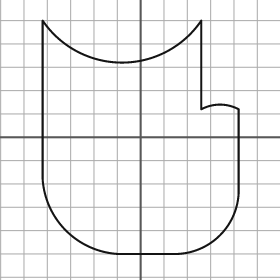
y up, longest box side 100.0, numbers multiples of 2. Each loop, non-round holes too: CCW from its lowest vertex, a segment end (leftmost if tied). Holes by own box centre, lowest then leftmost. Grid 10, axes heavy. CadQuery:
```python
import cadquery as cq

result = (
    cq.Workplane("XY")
    .moveTo(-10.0, -50.0)
    .lineTo(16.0, -50.0)
    .threePointArc((34.0, -42.0), (42.0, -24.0))
    .lineTo(42.0, 12.0)
    .threePointArc((34.0, 14.0), (26.0, 12.0))
    .lineTo(26.0, 50.0)
    .threePointArc((-8.0, 32.0), (-42.0, 50.0))
    .lineTo(-42.0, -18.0)
    .threePointArc((-32.0, -40.0), (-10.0, -50.0))
    .close()
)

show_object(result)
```